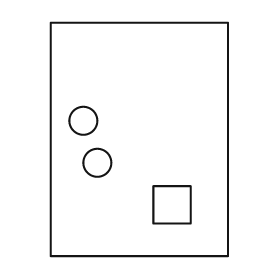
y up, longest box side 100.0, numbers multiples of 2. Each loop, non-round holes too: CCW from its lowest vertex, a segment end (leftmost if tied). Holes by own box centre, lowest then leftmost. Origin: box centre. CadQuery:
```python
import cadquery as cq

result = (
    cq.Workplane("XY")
    .moveTo(-38.0, -50.0)
    .lineTo(38.0, -50.0)
    .lineTo(38.0, 50.0)
    .lineTo(-38.0, 50.0)
    .close()
    .moveTo(6.0, -36.0)
    .lineTo(22.0, -36.0)
    .lineTo(22.0, -20.0)
    .lineTo(6.0, -20.0)
    .close()
    .moveTo(-18.0, -10.0)
    .circle(6.0)
    .moveTo(-24.0, 8.0)
    .circle(6.0)
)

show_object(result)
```